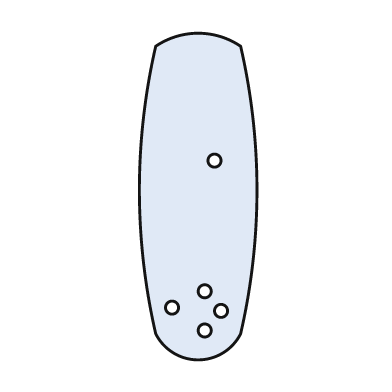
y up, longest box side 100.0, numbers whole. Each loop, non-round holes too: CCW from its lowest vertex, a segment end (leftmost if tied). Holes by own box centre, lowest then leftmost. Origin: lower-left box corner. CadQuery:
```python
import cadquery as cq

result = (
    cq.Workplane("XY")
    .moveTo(5.0, 8.0)
    .threePointArc((18.0, 0.0), (31.0, 8.0))
    .threePointArc((36.0, 52.0), (31.0, 96.0))
    .threePointArc((18.0, 100.0), (5.0, 96.0))
    .threePointArc((0.0, 52.0), (5.0, 8.0))
    .close()
    .moveTo(20.0, 9.0)
    .circle(2.0)
    .moveTo(25.0, 15.0)
    .circle(2.0)
    .moveTo(10.0, 16.0)
    .circle(2.0)
    .moveTo(20.0, 21.0)
    .circle(2.0)
    .moveTo(23.0, 61.0)
    .circle(2.0)
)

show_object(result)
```